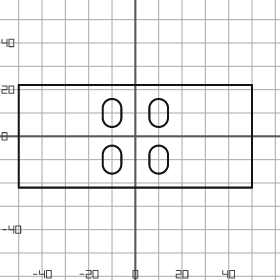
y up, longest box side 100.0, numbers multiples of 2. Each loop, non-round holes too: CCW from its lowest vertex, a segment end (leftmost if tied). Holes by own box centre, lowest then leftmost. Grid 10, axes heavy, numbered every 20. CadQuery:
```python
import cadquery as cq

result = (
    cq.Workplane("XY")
    .moveTo(-50.0, -22.0)
    .lineTo(50.0, -22.0)
    .lineTo(50.0, 22.0)
    .lineTo(-50.0, 22.0)
    .close()
    .moveTo(-14.0, -12.0)
    .threePointArc((-10.0, -16.0), (-6.0, -12.0))
    .lineTo(-6.0, -8.0)
    .threePointArc((-10.0, -4.0), (-14.0, -8.0))
    .close()
    .moveTo(6.0, -12.0)
    .threePointArc((10.0, -16.0), (14.0, -12.0))
    .lineTo(14.0, -8.0)
    .threePointArc((10.0, -4.0), (6.0, -8.0))
    .close()
    .moveTo(-14.0, 8.0)
    .threePointArc((-10.0, 4.0), (-6.0, 8.0))
    .lineTo(-6.0, 12.0)
    .threePointArc((-10.0, 16.0), (-14.0, 12.0))
    .close()
    .moveTo(6.0, 8.0)
    .threePointArc((10.0, 4.0), (14.0, 8.0))
    .lineTo(14.0, 12.0)
    .threePointArc((10.0, 16.0), (6.0, 12.0))
    .close()
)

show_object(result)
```